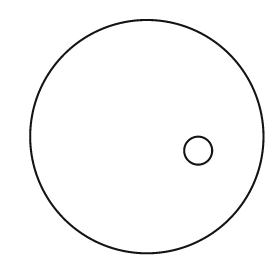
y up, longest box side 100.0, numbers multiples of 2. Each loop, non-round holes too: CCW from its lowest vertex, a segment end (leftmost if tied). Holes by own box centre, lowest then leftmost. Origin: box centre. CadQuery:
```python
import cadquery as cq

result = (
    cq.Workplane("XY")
    .moveTo(0.0, 0.0)
    .circle(50.0)
    .moveTo(22.0, -6.0)
    .circle(6.0)
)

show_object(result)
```